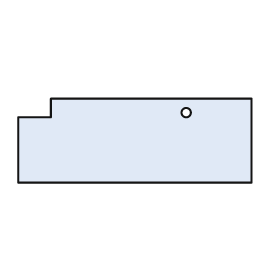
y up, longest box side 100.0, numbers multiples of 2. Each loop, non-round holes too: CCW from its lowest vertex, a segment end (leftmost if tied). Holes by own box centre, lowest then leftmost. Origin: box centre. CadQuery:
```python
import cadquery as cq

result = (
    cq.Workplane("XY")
    .moveTo(-50.0, -18.0)
    .lineTo(50.0, -18.0)
    .lineTo(50.0, 18.0)
    .lineTo(-36.0, 18.0)
    .lineTo(-36.0, 10.0)
    .lineTo(-50.0, 10.0)
    .close()
    .moveTo(22.0, 12.0)
    .circle(2.0)
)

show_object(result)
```